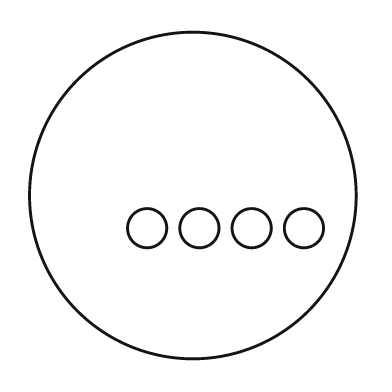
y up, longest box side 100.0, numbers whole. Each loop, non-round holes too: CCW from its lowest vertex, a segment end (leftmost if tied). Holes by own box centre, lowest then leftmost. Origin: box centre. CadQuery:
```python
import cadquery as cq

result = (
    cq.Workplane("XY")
    .moveTo(0.0, 0.0)
    .circle(50.0)
    .moveTo(-14.0, -10.0)
    .circle(6.0)
    .moveTo(2.0, -10.0)
    .circle(6.0)
    .moveTo(18.0, -10.0)
    .circle(6.0)
    .moveTo(34.0, -10.0)
    .circle(6.0)
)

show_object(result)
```